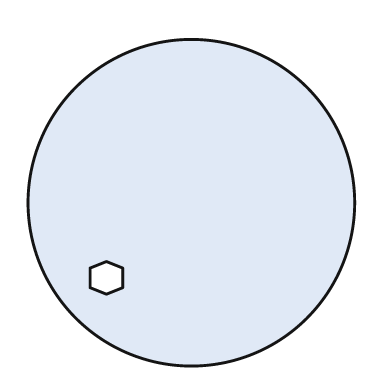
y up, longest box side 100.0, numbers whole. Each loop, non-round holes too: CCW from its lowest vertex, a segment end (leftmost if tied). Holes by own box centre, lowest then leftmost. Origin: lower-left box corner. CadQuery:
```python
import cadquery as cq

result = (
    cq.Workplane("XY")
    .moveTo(50.0, 50.0)
    .circle(50.0)
    .moveTo(24.0, 22.0)
    .lineTo(29.0, 24.0)
    .lineTo(29.0, 30.0)
    .lineTo(24.0, 32.0)
    .lineTo(19.0, 30.0)
    .lineTo(19.0, 24.0)
    .close()
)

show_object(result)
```